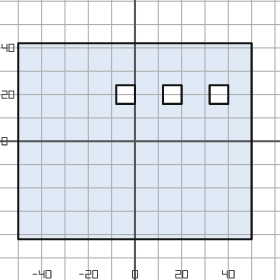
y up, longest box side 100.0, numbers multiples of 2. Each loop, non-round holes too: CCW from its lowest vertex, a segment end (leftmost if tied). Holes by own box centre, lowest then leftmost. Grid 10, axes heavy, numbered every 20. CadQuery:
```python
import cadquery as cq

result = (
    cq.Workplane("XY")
    .moveTo(-50.0, -42.0)
    .lineTo(50.0, -42.0)
    .lineTo(50.0, 42.0)
    .lineTo(-50.0, 42.0)
    .close()
    .moveTo(-8.0, 16.0)
    .lineTo(0.0, 16.0)
    .lineTo(0.0, 24.0)
    .lineTo(-8.0, 24.0)
    .close()
    .moveTo(12.0, 16.0)
    .lineTo(20.0, 16.0)
    .lineTo(20.0, 24.0)
    .lineTo(12.0, 24.0)
    .close()
    .moveTo(32.0, 16.0)
    .lineTo(40.0, 16.0)
    .lineTo(40.0, 24.0)
    .lineTo(32.0, 24.0)
    .close()
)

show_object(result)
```